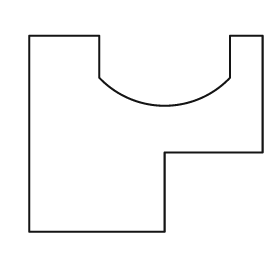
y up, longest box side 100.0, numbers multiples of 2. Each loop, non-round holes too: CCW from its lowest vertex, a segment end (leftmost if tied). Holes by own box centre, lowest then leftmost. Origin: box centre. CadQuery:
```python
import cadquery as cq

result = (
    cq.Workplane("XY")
    .moveTo(-50.0, -42.0)
    .lineTo(8.0, -42.0)
    .lineTo(8.0, -8.0)
    .lineTo(50.0, -8.0)
    .lineTo(50.0, 42.0)
    .lineTo(36.0, 42.0)
    .lineTo(36.0, 24.0)
    .threePointArc((8.0, 12.0), (-20.0, 24.0))
    .lineTo(-20.0, 42.0)
    .lineTo(-50.0, 42.0)
    .close()
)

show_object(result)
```